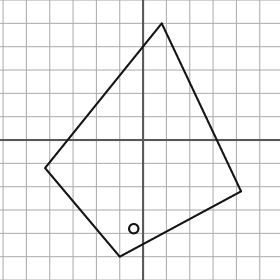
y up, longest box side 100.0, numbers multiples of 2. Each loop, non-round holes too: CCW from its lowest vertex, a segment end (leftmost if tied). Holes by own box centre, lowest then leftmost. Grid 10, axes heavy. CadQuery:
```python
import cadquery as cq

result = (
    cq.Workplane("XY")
    .moveTo(-10.0, -50.0)
    .lineTo(42.0, -22.0)
    .lineTo(8.0, 50.0)
    .lineTo(-42.0, -12.0)
    .close()
    .moveTo(-4.0, -38.0)
    .circle(2.0)
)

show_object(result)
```